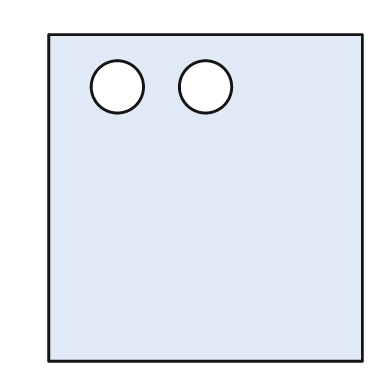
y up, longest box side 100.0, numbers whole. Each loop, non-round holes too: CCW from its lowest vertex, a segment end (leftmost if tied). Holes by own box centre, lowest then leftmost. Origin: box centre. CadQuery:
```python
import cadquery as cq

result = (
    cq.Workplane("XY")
    .moveTo(-48.0, -50.0)
    .lineTo(48.0, -50.0)
    .lineTo(48.0, 50.0)
    .lineTo(-48.0, 50.0)
    .close()
    .moveTo(-27.0, 34.0)
    .circle(8.0)
    .moveTo(0.0, 34.0)
    .circle(8.0)
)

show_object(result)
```